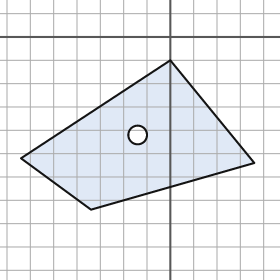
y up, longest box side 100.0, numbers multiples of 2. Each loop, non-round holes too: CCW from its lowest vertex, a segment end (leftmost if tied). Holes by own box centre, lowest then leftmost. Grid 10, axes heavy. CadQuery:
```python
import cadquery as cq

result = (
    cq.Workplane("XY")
    .moveTo(-34.0, -74.0)
    .lineTo(36.0, -54.0)
    .lineTo(0.0, -10.0)
    .lineTo(-64.0, -52.0)
    .close()
    .moveTo(-14.0, -42.0)
    .circle(4.0)
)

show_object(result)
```